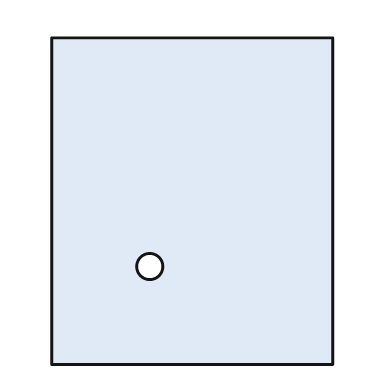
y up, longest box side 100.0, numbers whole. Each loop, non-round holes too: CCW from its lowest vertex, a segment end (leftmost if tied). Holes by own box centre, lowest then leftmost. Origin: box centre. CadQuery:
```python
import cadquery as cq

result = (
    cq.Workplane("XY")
    .moveTo(-43.0, -50.0)
    .lineTo(43.0, -50.0)
    .lineTo(43.0, 50.0)
    .lineTo(-43.0, 50.0)
    .close()
    .moveTo(-13.0, -20.0)
    .circle(4.0)
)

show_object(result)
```